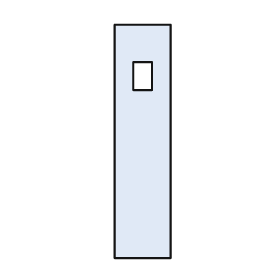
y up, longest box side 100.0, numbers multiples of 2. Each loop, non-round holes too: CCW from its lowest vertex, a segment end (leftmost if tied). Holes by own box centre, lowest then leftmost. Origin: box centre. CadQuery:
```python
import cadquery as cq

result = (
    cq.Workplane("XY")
    .moveTo(-12.0, -50.0)
    .lineTo(12.0, -50.0)
    .lineTo(12.0, 50.0)
    .lineTo(-12.0, 50.0)
    .close()
    .moveTo(-4.0, 22.0)
    .lineTo(4.0, 22.0)
    .lineTo(4.0, 34.0)
    .lineTo(-4.0, 34.0)
    .close()
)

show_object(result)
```